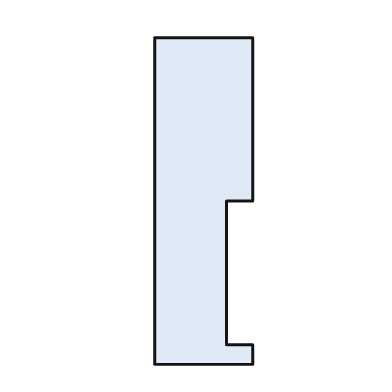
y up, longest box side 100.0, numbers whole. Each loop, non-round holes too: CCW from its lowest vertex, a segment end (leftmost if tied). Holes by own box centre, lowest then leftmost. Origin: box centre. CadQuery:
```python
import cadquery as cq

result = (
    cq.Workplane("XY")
    .moveTo(-15.0, -50.0)
    .lineTo(15.0, -50.0)
    .lineTo(15.0, -44.0)
    .lineTo(7.0, -44.0)
    .lineTo(7.0, 0.0)
    .lineTo(15.0, 0.0)
    .lineTo(15.0, 50.0)
    .lineTo(-15.0, 50.0)
    .close()
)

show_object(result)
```